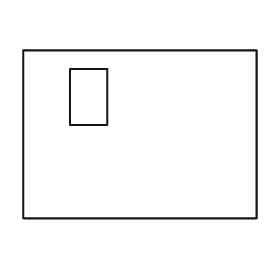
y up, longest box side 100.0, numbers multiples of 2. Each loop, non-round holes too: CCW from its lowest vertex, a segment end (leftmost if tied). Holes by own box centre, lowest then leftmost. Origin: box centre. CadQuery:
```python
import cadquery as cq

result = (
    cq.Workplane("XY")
    .moveTo(-50.0, -36.0)
    .lineTo(50.0, -36.0)
    .lineTo(50.0, 36.0)
    .lineTo(-50.0, 36.0)
    .close()
    .moveTo(-30.0, 4.0)
    .lineTo(-14.0, 4.0)
    .lineTo(-14.0, 28.0)
    .lineTo(-30.0, 28.0)
    .close()
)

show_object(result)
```